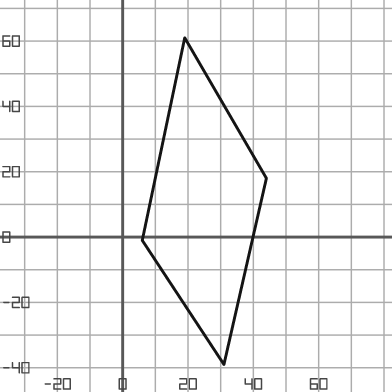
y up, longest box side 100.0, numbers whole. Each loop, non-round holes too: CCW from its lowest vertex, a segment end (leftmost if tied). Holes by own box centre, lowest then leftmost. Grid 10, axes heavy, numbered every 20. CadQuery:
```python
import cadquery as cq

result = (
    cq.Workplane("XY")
    .moveTo(31.0, -39.0)
    .lineTo(44.0, 18.0)
    .lineTo(19.0, 61.0)
    .lineTo(6.0, -1.0)
    .close()
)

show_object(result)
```